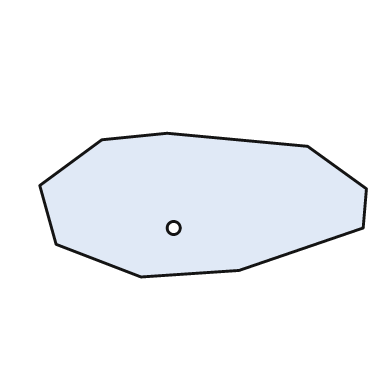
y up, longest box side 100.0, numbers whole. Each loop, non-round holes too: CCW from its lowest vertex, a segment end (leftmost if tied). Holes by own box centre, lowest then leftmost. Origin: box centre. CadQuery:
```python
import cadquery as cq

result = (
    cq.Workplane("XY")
    .moveTo(-19.0, -22.0)
    .lineTo(11.0, -20.0)
    .lineTo(49.0, -7.0)
    .lineTo(50.0, 5.0)
    .lineTo(32.0, 18.0)
    .lineTo(-11.0, 22.0)
    .lineTo(-31.0, 20.0)
    .lineTo(-50.0, 6.0)
    .lineTo(-45.0, -12.0)
    .close()
    .moveTo(-9.0, -7.0)
    .circle(2.0)
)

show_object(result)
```